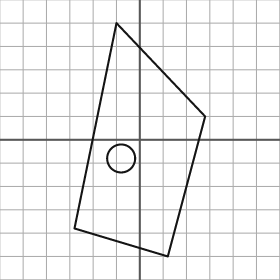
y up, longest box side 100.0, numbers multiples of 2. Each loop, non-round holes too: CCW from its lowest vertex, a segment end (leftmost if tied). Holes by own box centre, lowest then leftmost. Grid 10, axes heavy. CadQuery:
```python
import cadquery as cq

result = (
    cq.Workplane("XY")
    .moveTo(12.0, -50.0)
    .lineTo(28.0, 10.0)
    .lineTo(-10.0, 50.0)
    .lineTo(-28.0, -38.0)
    .close()
    .moveTo(-8.0, -8.0)
    .circle(6.0)
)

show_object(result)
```